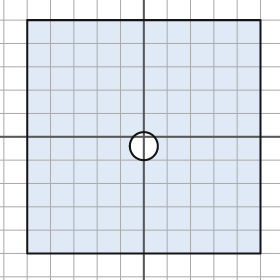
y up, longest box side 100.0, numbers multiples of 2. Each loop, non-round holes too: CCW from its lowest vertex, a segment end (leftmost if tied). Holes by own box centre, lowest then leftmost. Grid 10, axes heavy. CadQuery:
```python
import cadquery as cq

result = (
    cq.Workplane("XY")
    .moveTo(-50.0, -50.0)
    .lineTo(50.0, -50.0)
    .lineTo(50.0, 50.0)
    .lineTo(-50.0, 50.0)
    .close()
    .moveTo(0.0, -4.0)
    .circle(6.0)
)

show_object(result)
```